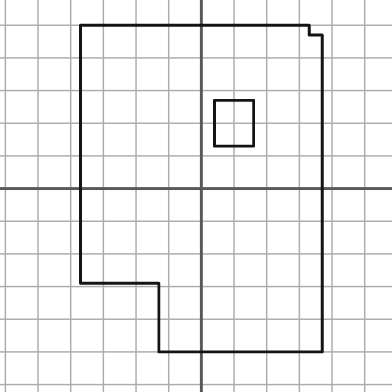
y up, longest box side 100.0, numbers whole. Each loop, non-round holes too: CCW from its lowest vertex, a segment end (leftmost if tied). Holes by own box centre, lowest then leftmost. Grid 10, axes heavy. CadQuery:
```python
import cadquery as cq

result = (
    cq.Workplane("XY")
    .moveTo(-13.0, -50.0)
    .lineTo(37.0, -50.0)
    .lineTo(37.0, 47.0)
    .lineTo(33.0, 47.0)
    .lineTo(33.0, 50.0)
    .lineTo(-37.0, 50.0)
    .lineTo(-37.0, -29.0)
    .lineTo(-13.0, -29.0)
    .close()
    .moveTo(4.0, 13.0)
    .lineTo(16.0, 13.0)
    .lineTo(16.0, 27.0)
    .lineTo(4.0, 27.0)
    .close()
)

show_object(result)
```